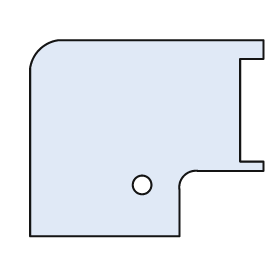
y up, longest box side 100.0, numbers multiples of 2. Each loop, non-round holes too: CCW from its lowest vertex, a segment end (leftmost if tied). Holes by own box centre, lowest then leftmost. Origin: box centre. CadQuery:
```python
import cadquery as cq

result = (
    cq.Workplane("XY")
    .moveTo(-50.0, -42.0)
    .lineTo(14.0, -42.0)
    .lineTo(14.0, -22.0)
    .threePointArc((16.0, -16.0), (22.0, -14.0))
    .lineTo(50.0, -14.0)
    .lineTo(50.0, -10.0)
    .lineTo(40.0, -10.0)
    .lineTo(40.0, 34.0)
    .lineTo(50.0, 34.0)
    .lineTo(50.0, 42.0)
    .lineTo(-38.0, 42.0)
    .threePointArc((-46.0, 38.0), (-50.0, 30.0))
    .close()
    .moveTo(-2.0, -20.0)
    .circle(4.0)
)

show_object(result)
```